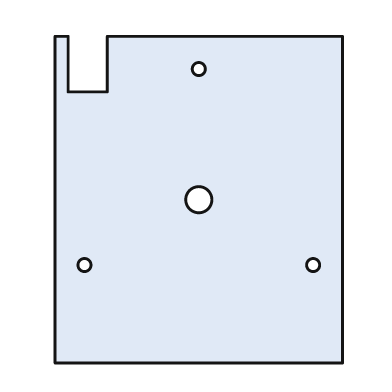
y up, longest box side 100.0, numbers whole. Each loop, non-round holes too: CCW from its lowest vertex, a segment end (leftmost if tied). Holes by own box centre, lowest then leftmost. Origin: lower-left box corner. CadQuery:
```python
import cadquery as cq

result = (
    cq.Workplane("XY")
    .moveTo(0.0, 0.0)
    .lineTo(88.0, 0.0)
    .lineTo(88.0, 100.0)
    .lineTo(16.0, 100.0)
    .lineTo(16.0, 83.0)
    .lineTo(4.0, 83.0)
    .lineTo(4.0, 100.0)
    .lineTo(0.0, 100.0)
    .close()
    .moveTo(9.0, 30.0)
    .circle(2.0)
    .moveTo(79.0, 30.0)
    .circle(2.0)
    .moveTo(44.0, 50.0)
    .circle(4.0)
    .moveTo(44.0, 90.0)
    .circle(2.0)
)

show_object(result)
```